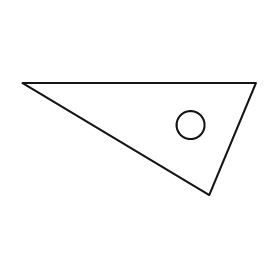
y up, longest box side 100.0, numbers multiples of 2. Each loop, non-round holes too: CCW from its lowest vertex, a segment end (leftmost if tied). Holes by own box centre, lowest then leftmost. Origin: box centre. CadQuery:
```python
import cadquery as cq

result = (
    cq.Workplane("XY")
    .moveTo(30.0, -24.0)
    .lineTo(50.0, 24.0)
    .lineTo(-50.0, 24.0)
    .close()
    .moveTo(22.0, 6.0)
    .circle(6.0)
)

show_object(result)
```